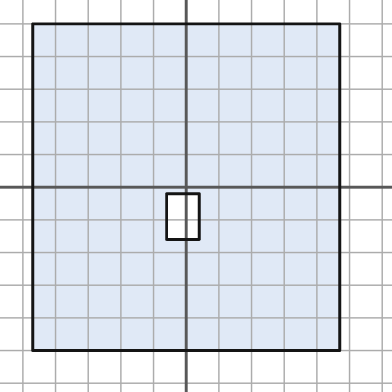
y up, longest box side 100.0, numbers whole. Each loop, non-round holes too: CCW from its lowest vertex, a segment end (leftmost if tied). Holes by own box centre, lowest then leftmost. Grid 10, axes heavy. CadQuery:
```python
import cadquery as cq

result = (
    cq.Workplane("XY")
    .moveTo(-47.0, -50.0)
    .lineTo(47.0, -50.0)
    .lineTo(47.0, 50.0)
    .lineTo(-47.0, 50.0)
    .close()
    .moveTo(-6.0, -16.0)
    .lineTo(4.0, -16.0)
    .lineTo(4.0, -2.0)
    .lineTo(-6.0, -2.0)
    .close()
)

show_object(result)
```